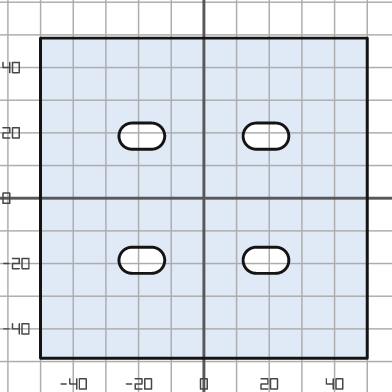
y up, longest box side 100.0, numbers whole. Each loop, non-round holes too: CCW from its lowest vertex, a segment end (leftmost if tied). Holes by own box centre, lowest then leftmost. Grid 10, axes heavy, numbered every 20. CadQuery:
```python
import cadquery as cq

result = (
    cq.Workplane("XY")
    .moveTo(-50.0, -49.0)
    .lineTo(50.0, -49.0)
    .lineTo(50.0, 49.0)
    .lineTo(-50.0, 49.0)
    .close()
    .moveTo(-22.0, -23.0)
    .lineTo(-16.0, -23.0)
    .threePointArc((-12.0, -19.0), (-16.0, -15.0))
    .lineTo(-22.0, -15.0)
    .threePointArc((-26.0, -19.0), (-22.0, -23.0))
    .close()
    .moveTo(16.0, -23.0)
    .lineTo(22.0, -23.0)
    .threePointArc((26.0, -19.0), (22.0, -15.0))
    .lineTo(16.0, -15.0)
    .threePointArc((12.0, -19.0), (16.0, -23.0))
    .close()
    .moveTo(-22.0, 15.0)
    .lineTo(-16.0, 15.0)
    .threePointArc((-12.0, 19.0), (-16.0, 23.0))
    .lineTo(-22.0, 23.0)
    .threePointArc((-26.0, 19.0), (-22.0, 15.0))
    .close()
    .moveTo(16.0, 15.0)
    .lineTo(22.0, 15.0)
    .threePointArc((26.0, 19.0), (22.0, 23.0))
    .lineTo(16.0, 23.0)
    .threePointArc((12.0, 19.0), (16.0, 15.0))
    .close()
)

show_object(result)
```